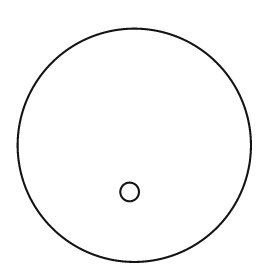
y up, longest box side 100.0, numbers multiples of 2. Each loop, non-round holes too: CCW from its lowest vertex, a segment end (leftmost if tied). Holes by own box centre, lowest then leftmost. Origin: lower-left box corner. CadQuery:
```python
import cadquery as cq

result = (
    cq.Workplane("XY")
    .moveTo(50.0, 50.0)
    .circle(50.0)
    .moveTo(48.0, 30.0)
    .circle(4.0)
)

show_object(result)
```